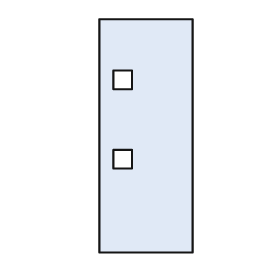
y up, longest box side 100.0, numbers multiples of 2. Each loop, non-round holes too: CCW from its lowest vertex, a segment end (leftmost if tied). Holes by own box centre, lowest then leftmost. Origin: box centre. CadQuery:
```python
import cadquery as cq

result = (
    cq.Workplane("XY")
    .moveTo(-20.0, -50.0)
    .lineTo(20.0, -50.0)
    .lineTo(20.0, 50.0)
    .lineTo(-20.0, 50.0)
    .close()
    .moveTo(-14.0, -14.0)
    .lineTo(-6.0, -14.0)
    .lineTo(-6.0, -6.0)
    .lineTo(-14.0, -6.0)
    .close()
    .moveTo(-14.0, 20.0)
    .lineTo(-6.0, 20.0)
    .lineTo(-6.0, 28.0)
    .lineTo(-14.0, 28.0)
    .close()
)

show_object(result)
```